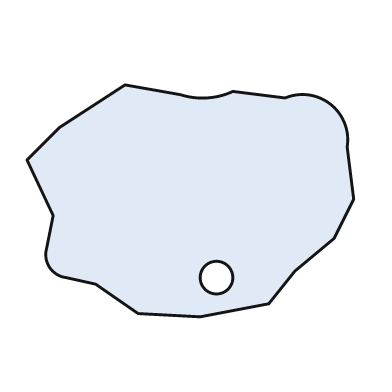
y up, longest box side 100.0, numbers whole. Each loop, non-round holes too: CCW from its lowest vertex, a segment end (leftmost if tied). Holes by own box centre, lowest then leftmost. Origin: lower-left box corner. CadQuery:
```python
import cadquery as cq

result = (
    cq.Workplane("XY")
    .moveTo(53.0, 0.0)
    .lineTo(74.0, 4.0)
    .lineTo(82.0, 14.0)
    .lineTo(94.0, 24.0)
    .lineTo(100.0, 36.0)
    .lineTo(98.0, 52.0)
    .threePointArc((93.0, 65.0), (79.0, 67.0))
    .lineTo(63.0, 69.0)
    .threePointArc((55.0, 67.0), (47.0, 68.0))
    .lineTo(30.0, 71.0)
    .lineTo(10.0, 58.0)
    .lineTo(0.0, 48.0)
    .lineTo(8.0, 31.0)
    .lineTo(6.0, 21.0)
    .threePointArc((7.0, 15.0), (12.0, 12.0))
    .lineTo(21.0, 10.0)
    .lineTo(34.0, 1.0)
    .close()
    .moveTo(58.0, 12.0)
    .circle(5.0)
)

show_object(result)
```